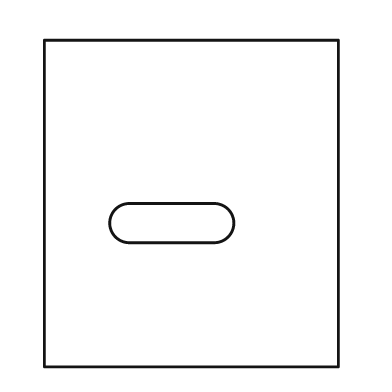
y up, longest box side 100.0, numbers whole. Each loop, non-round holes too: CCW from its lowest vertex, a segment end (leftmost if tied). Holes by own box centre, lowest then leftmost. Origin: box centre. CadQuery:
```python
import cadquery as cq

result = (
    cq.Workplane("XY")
    .moveTo(-45.0, -50.0)
    .lineTo(45.0, -50.0)
    .lineTo(45.0, 50.0)
    .lineTo(-45.0, 50.0)
    .close()
    .moveTo(-19.0, -12.0)
    .lineTo(7.0, -12.0)
    .threePointArc((13.0, -6.0), (7.0, 0.0))
    .lineTo(-19.0, 0.0)
    .threePointArc((-25.0, -6.0), (-19.0, -12.0))
    .close()
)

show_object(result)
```